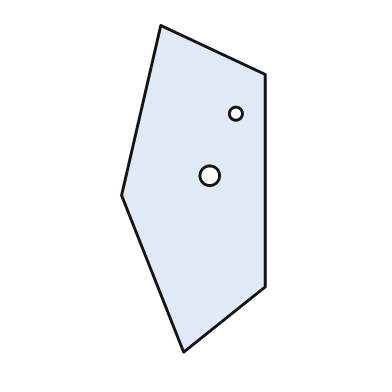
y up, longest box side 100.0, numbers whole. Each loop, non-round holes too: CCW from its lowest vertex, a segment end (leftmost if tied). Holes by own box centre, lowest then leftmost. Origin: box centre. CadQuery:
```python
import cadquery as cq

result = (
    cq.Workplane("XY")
    .moveTo(-3.0, -50.0)
    .lineTo(22.0, -30.0)
    .lineTo(22.0, 35.0)
    .lineTo(-10.0, 50.0)
    .lineTo(-22.0, -2.0)
    .close()
    .moveTo(5.0, 4.0)
    .circle(3.0)
    .moveTo(13.0, 23.0)
    .circle(2.0)
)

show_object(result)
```